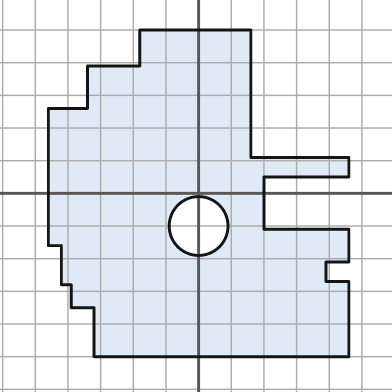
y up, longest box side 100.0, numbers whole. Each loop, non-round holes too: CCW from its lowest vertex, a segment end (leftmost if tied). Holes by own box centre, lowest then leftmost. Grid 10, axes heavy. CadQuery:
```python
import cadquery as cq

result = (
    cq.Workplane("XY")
    .moveTo(-32.0, -50.0)
    .lineTo(46.0, -50.0)
    .lineTo(46.0, -27.0)
    .lineTo(39.0, -27.0)
    .lineTo(39.0, -21.0)
    .lineTo(46.0, -21.0)
    .lineTo(46.0, -11.0)
    .lineTo(20.0, -11.0)
    .lineTo(20.0, 5.0)
    .lineTo(46.0, 5.0)
    .lineTo(46.0, 11.0)
    .lineTo(16.0, 11.0)
    .lineTo(16.0, 50.0)
    .lineTo(-18.0, 50.0)
    .lineTo(-18.0, 39.0)
    .lineTo(-34.0, 39.0)
    .lineTo(-34.0, 26.0)
    .lineTo(-46.0, 26.0)
    .lineTo(-46.0, -16.0)
    .lineTo(-42.0, -16.0)
    .lineTo(-42.0, -28.0)
    .lineTo(-39.0, -28.0)
    .lineTo(-39.0, -35.0)
    .lineTo(-32.0, -35.0)
    .close()
    .moveTo(0.0, -10.0)
    .circle(9.0)
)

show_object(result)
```